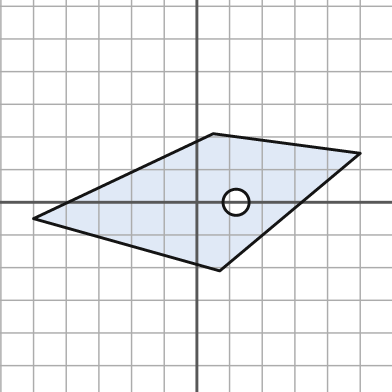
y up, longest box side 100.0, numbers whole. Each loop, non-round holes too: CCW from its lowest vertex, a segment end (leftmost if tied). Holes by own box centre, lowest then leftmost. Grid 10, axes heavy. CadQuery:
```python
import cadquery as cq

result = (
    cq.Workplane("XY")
    .moveTo(7.0, -21.0)
    .lineTo(50.0, 15.0)
    .lineTo(5.0, 21.0)
    .lineTo(-50.0, -5.0)
    .close()
    .moveTo(12.0, 0.0)
    .circle(4.0)
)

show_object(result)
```